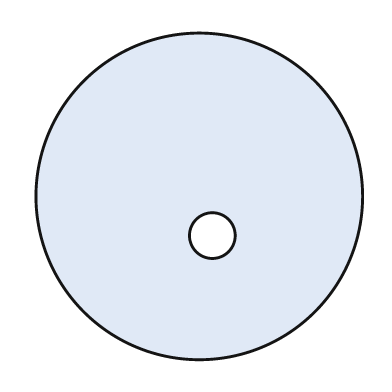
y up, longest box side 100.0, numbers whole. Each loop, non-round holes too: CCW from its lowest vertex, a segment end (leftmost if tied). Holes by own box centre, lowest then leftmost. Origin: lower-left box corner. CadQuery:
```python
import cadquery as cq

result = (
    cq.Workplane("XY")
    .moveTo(50.0, 50.0)
    .circle(50.0)
    .moveTo(54.0, 38.0)
    .circle(7.0)
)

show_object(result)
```